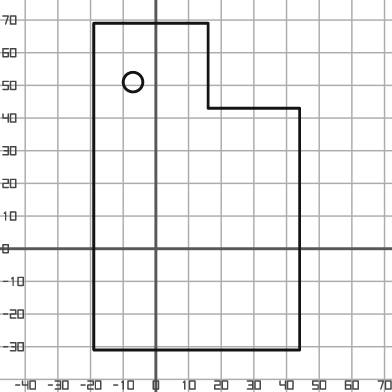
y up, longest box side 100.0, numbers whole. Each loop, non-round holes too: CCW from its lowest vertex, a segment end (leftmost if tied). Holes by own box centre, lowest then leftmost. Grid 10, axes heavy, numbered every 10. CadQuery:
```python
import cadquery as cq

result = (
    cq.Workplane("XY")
    .moveTo(-19.0, -31.0)
    .lineTo(44.0, -31.0)
    .lineTo(44.0, 43.0)
    .lineTo(16.0, 43.0)
    .lineTo(16.0, 69.0)
    .lineTo(-19.0, 69.0)
    .close()
    .moveTo(-7.0, 51.0)
    .circle(3.0)
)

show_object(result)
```